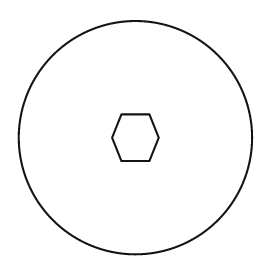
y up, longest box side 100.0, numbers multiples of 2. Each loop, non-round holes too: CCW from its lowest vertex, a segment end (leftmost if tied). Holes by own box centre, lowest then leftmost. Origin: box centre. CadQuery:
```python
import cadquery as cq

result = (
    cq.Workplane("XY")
    .moveTo(0.0, 0.0)
    .circle(50.0)
    .moveTo(-6.0, -10.0)
    .lineTo(6.0, -10.0)
    .lineTo(10.0, 0.0)
    .lineTo(6.0, 10.0)
    .lineTo(-6.0, 10.0)
    .lineTo(-10.0, 0.0)
    .close()
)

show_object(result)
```